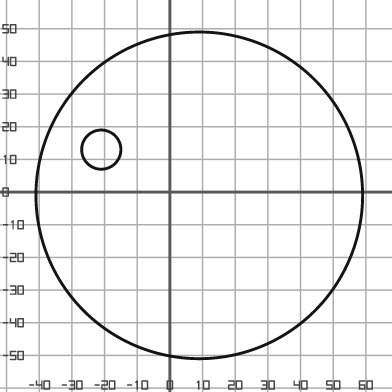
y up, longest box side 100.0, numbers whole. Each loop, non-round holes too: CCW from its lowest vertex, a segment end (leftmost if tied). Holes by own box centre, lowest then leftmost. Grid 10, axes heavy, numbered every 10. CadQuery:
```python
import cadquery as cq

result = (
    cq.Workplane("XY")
    .moveTo(9.0, -1.0)
    .circle(50.0)
    .moveTo(-21.0, 13.0)
    .circle(6.0)
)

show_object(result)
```